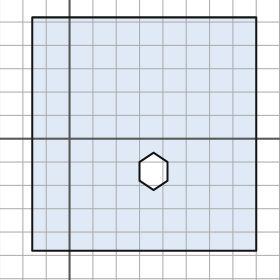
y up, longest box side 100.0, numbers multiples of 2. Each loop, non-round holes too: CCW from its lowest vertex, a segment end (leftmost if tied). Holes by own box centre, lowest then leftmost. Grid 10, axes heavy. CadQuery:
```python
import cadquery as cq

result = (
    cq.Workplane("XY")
    .moveTo(-16.0, -48.0)
    .lineTo(80.0, -48.0)
    .lineTo(80.0, 52.0)
    .lineTo(-16.0, 52.0)
    .close()
    .moveTo(36.0, -22.0)
    .lineTo(42.0, -18.0)
    .lineTo(42.0, -10.0)
    .lineTo(36.0, -6.0)
    .lineTo(30.0, -10.0)
    .lineTo(30.0, -18.0)
    .close()
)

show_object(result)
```